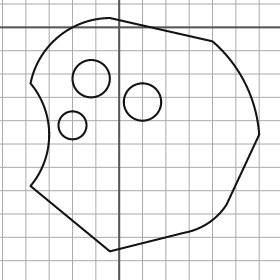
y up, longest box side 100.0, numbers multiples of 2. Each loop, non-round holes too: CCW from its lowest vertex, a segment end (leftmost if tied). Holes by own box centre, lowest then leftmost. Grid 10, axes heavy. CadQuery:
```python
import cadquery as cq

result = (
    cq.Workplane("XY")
    .moveTo(-4.0, -96.0)
    .lineTo(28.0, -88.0)
    .threePointArc((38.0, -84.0), (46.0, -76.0))
    .lineTo(60.0, -46.0)
    .threePointArc((54.0, -24.0), (40.0, -6.0))
    .lineTo(-4.0, 4.0)
    .threePointArc((-26.0, -4.0), (-38.0, -24.0))
    .threePointArc((-30.0, -46.0), (-38.0, -68.0))
    .close()
    .moveTo(-20.0, -42.0)
    .circle(6.0)
    .moveTo(10.0, -32.0)
    .circle(8.0)
    .moveTo(-12.0, -22.0)
    .circle(8.0)
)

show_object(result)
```